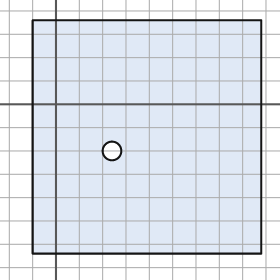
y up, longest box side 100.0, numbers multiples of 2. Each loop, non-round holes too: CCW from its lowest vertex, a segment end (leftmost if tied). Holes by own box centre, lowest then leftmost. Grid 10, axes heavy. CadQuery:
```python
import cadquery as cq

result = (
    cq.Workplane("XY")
    .moveTo(-10.0, -64.0)
    .lineTo(88.0, -64.0)
    .lineTo(88.0, 36.0)
    .lineTo(-10.0, 36.0)
    .close()
    .moveTo(24.0, -20.0)
    .circle(4.0)
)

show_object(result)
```